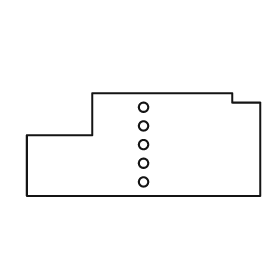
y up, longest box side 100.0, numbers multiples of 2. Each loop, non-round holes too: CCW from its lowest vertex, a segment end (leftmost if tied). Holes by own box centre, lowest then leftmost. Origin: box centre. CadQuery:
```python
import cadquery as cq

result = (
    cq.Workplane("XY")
    .moveTo(-50.0, -22.0)
    .lineTo(50.0, -22.0)
    .lineTo(50.0, 18.0)
    .lineTo(38.0, 18.0)
    .lineTo(38.0, 22.0)
    .lineTo(-22.0, 22.0)
    .lineTo(-22.0, 4.0)
    .lineTo(-50.0, 4.0)
    .close()
    .moveTo(0.0, -16.0)
    .circle(2.0)
    .moveTo(0.0, -8.0)
    .circle(2.0)
    .moveTo(0.0, 0.0)
    .circle(2.0)
    .moveTo(0.0, 8.0)
    .circle(2.0)
    .moveTo(0.0, 16.0)
    .circle(2.0)
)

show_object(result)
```